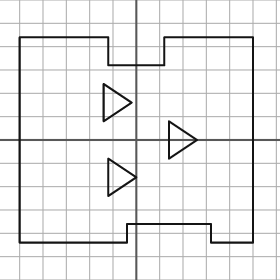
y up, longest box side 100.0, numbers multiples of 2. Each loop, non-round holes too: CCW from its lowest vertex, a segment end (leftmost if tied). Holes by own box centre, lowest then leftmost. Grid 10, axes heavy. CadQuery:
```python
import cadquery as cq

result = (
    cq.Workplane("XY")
    .moveTo(-50.0, -44.0)
    .lineTo(-4.0, -44.0)
    .lineTo(-4.0, -36.0)
    .lineTo(32.0, -36.0)
    .lineTo(32.0, -44.0)
    .lineTo(50.0, -44.0)
    .lineTo(50.0, 44.0)
    .lineTo(12.0, 44.0)
    .lineTo(12.0, 32.0)
    .lineTo(-12.0, 32.0)
    .lineTo(-12.0, 44.0)
    .lineTo(-50.0, 44.0)
    .close()
    .moveTo(-12.0, -24.0)
    .lineTo(0.0, -16.0)
    .lineTo(-12.0, -8.0)
    .close()
    .moveTo(14.0, -8.0)
    .lineTo(26.0, 0.0)
    .lineTo(14.0, 8.0)
    .close()
    .moveTo(-14.0, 8.0)
    .lineTo(-2.0, 16.0)
    .lineTo(-14.0, 24.0)
    .close()
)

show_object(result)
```